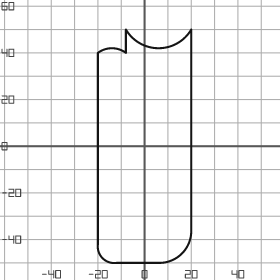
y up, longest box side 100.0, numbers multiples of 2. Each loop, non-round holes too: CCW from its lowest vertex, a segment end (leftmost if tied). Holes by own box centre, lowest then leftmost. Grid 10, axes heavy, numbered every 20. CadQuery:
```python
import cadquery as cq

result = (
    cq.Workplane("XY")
    .moveTo(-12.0, -50.0)
    .lineTo(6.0, -50.0)
    .threePointArc((16.0, -46.0), (20.0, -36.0))
    .lineTo(20.0, 50.0)
    .threePointArc((6.0, 42.0), (-8.0, 50.0))
    .lineTo(-8.0, 40.0)
    .threePointArc((-14.0, 42.0), (-20.0, 40.0))
    .lineTo(-20.0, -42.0)
    .threePointArc((-18.0, -48.0), (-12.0, -50.0))
    .close()
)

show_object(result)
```